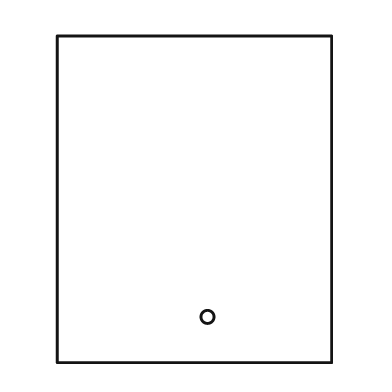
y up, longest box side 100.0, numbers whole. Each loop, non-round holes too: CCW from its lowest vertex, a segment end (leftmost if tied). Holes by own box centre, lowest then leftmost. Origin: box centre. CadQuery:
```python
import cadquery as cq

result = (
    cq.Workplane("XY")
    .moveTo(-42.0, -50.0)
    .lineTo(42.0, -50.0)
    .lineTo(42.0, 50.0)
    .lineTo(-42.0, 50.0)
    .close()
    .moveTo(4.0, -36.0)
    .circle(2.0)
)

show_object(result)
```